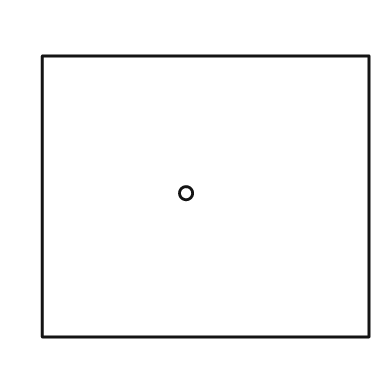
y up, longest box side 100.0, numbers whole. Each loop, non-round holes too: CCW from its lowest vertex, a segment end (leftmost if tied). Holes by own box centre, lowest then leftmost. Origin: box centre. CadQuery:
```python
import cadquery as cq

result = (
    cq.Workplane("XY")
    .moveTo(-50.0, -43.0)
    .lineTo(50.0, -43.0)
    .lineTo(50.0, 43.0)
    .lineTo(-50.0, 43.0)
    .close()
    .moveTo(-6.0, 1.0)
    .circle(2.0)
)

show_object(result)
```